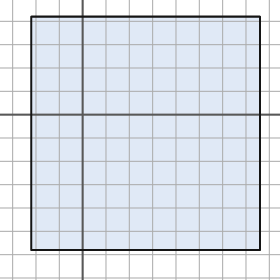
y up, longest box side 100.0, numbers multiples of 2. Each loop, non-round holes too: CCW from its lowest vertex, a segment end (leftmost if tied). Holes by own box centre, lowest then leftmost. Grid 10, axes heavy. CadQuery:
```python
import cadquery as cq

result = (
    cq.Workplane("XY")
    .moveTo(-22.0, -58.0)
    .lineTo(76.0, -58.0)
    .lineTo(76.0, 42.0)
    .lineTo(-22.0, 42.0)
    .close()
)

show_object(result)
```